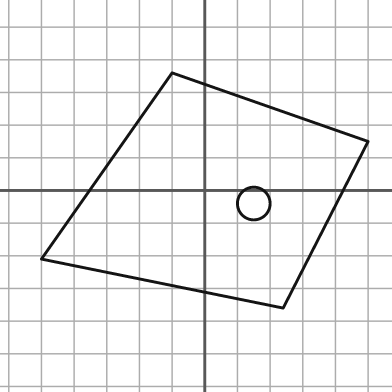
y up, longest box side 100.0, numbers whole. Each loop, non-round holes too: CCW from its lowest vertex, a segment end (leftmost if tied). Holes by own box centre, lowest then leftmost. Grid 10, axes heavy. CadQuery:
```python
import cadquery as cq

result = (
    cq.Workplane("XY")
    .moveTo(24.0, -36.0)
    .lineTo(50.0, 15.0)
    .lineTo(-10.0, 36.0)
    .lineTo(-50.0, -21.0)
    .close()
    .moveTo(15.0, -4.0)
    .circle(5.0)
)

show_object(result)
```